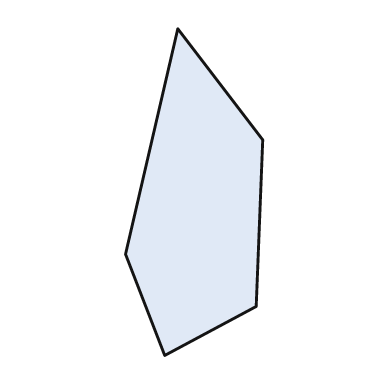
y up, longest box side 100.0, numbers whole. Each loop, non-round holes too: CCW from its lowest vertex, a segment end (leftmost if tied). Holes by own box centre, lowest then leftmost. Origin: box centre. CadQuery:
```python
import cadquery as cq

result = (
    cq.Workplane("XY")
    .moveTo(-9.0, -50.0)
    .lineTo(19.0, -35.0)
    .lineTo(21.0, 16.0)
    .lineTo(-5.0, 50.0)
    .lineTo(-21.0, -19.0)
    .close()
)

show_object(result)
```